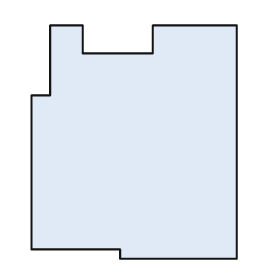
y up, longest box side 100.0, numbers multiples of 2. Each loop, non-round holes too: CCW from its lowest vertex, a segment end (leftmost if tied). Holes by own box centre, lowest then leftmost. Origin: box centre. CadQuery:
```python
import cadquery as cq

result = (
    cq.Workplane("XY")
    .moveTo(-6.0, -50.0)
    .lineTo(44.0, -50.0)
    .lineTo(44.0, 50.0)
    .lineTo(8.0, 50.0)
    .lineTo(8.0, 38.0)
    .lineTo(-22.0, 38.0)
    .lineTo(-22.0, 50.0)
    .lineTo(-36.0, 50.0)
    .lineTo(-36.0, 20.0)
    .lineTo(-44.0, 20.0)
    .lineTo(-44.0, -46.0)
    .lineTo(-6.0, -46.0)
    .close()
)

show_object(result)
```